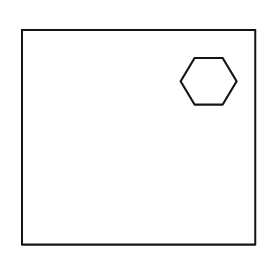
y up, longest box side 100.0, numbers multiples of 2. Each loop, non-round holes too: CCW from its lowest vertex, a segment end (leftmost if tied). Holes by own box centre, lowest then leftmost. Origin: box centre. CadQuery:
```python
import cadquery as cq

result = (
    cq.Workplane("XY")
    .moveTo(-50.0, -46.0)
    .lineTo(50.0, -46.0)
    .lineTo(50.0, 46.0)
    .lineTo(-50.0, 46.0)
    .close()
    .moveTo(24.0, 14.0)
    .lineTo(36.0, 14.0)
    .lineTo(42.0, 24.0)
    .lineTo(36.0, 34.0)
    .lineTo(24.0, 34.0)
    .lineTo(18.0, 24.0)
    .close()
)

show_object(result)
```